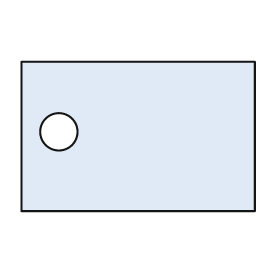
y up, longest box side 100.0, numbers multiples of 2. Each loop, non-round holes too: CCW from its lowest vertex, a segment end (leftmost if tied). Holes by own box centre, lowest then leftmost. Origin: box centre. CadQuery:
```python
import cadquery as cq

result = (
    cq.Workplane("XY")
    .moveTo(-50.0, -32.0)
    .lineTo(50.0, -32.0)
    .lineTo(50.0, 32.0)
    .lineTo(-50.0, 32.0)
    .close()
    .moveTo(-34.0, 2.0)
    .circle(8.0)
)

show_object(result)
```